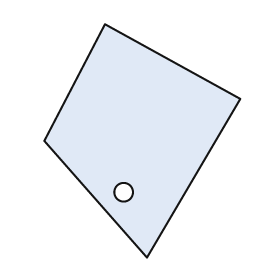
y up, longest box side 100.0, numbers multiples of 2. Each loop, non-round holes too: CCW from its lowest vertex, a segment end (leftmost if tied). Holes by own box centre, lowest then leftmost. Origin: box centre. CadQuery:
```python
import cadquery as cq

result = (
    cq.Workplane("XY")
    .moveTo(2.0, -50.0)
    .lineTo(42.0, 18.0)
    .lineTo(-16.0, 50.0)
    .lineTo(-42.0, 0.0)
    .close()
    .moveTo(-8.0, -22.0)
    .circle(4.0)
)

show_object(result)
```